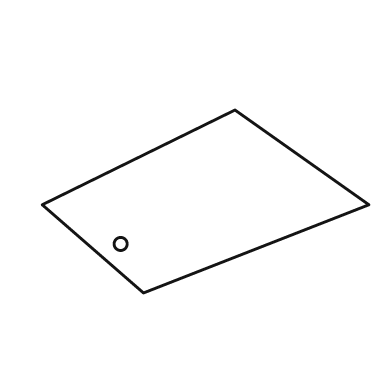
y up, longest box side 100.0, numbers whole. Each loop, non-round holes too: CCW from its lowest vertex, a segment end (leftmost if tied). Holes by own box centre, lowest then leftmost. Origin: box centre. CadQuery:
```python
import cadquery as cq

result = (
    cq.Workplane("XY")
    .moveTo(-19.0, -28.0)
    .lineTo(50.0, -1.0)
    .lineTo(9.0, 28.0)
    .lineTo(-50.0, -1.0)
    .close()
    .moveTo(-26.0, -13.0)
    .circle(2.0)
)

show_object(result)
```